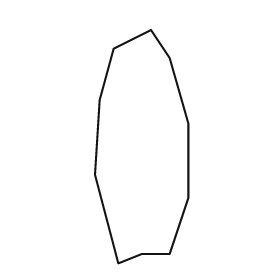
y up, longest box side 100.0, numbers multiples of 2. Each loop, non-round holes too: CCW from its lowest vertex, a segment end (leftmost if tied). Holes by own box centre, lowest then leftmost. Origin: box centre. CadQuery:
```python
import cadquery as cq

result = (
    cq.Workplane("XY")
    .moveTo(-10.0, -50.0)
    .lineTo(0.0, -46.0)
    .lineTo(12.0, -46.0)
    .lineTo(20.0, -22.0)
    .lineTo(20.0, 10.0)
    .lineTo(12.0, 38.0)
    .lineTo(4.0, 50.0)
    .lineTo(-12.0, 42.0)
    .lineTo(-18.0, 20.0)
    .lineTo(-20.0, -12.0)
    .close()
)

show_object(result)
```